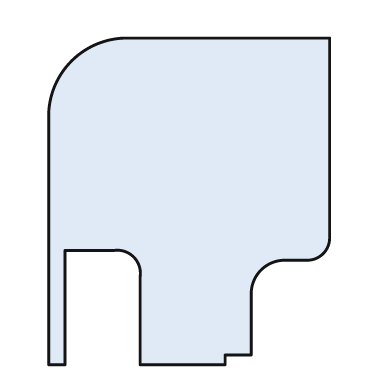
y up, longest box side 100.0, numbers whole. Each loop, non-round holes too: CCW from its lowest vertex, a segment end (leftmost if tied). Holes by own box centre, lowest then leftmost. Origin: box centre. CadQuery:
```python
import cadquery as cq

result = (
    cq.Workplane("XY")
    .moveTo(-43.0, -50.0)
    .lineTo(-38.0, -50.0)
    .lineTo(-38.0, -15.0)
    .lineTo(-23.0, -15.0)
    .threePointArc((-17.0, -17.0), (-15.0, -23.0))
    .lineTo(-15.0, -50.0)
    .lineTo(11.0, -50.0)
    .lineTo(11.0, -47.0)
    .lineTo(19.0, -47.0)
    .lineTo(19.0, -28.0)
    .threePointArc((22.0, -21.0), (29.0, -18.0))
    .lineTo(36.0, -18.0)
    .threePointArc((41.0, -16.0), (43.0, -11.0))
    .lineTo(43.0, 50.0)
    .lineTo(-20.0, 50.0)
    .threePointArc((-36.0, 43.0), (-43.0, 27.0))
    .close()
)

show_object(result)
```